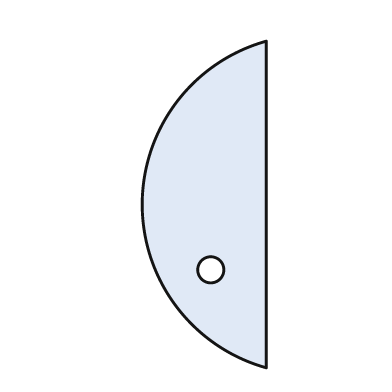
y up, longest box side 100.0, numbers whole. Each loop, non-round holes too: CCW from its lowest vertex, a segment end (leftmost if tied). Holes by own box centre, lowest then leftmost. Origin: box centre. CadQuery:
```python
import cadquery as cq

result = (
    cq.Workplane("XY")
    .moveTo(19.0, -50.0)
    .lineTo(19.0, 50.0)
    .threePointArc((-19.0, 0.0), (19.0, -50.0))
    .close()
    .moveTo(2.0, -20.0)
    .circle(4.0)
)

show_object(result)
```